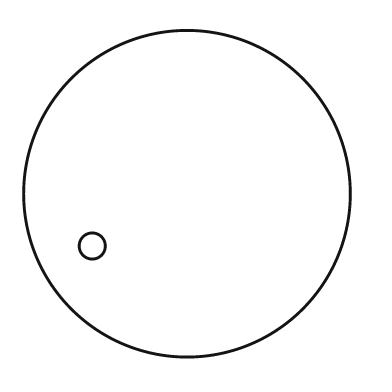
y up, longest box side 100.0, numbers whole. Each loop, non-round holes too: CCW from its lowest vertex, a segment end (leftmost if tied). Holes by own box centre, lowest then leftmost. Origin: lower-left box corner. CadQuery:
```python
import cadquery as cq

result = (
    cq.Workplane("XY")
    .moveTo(50.0, 50.0)
    .circle(50.0)
    .moveTo(21.0, 34.0)
    .circle(4.0)
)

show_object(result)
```